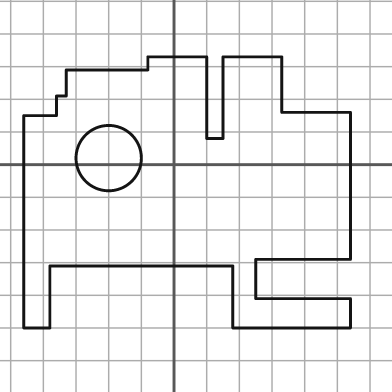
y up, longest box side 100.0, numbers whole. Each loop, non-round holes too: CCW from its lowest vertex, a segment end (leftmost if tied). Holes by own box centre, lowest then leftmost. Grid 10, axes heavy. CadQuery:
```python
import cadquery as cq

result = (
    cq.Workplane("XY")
    .moveTo(-46.0, -50.0)
    .lineTo(-38.0, -50.0)
    .lineTo(-38.0, -31.0)
    .lineTo(18.0, -31.0)
    .lineTo(18.0, -50.0)
    .lineTo(54.0, -50.0)
    .lineTo(54.0, -41.0)
    .lineTo(25.0, -41.0)
    .lineTo(25.0, -29.0)
    .lineTo(54.0, -29.0)
    .lineTo(54.0, 16.0)
    .lineTo(33.0, 16.0)
    .lineTo(33.0, 33.0)
    .lineTo(15.0, 33.0)
    .lineTo(15.0, 8.0)
    .lineTo(10.0, 8.0)
    .lineTo(10.0, 33.0)
    .lineTo(-8.0, 33.0)
    .lineTo(-8.0, 29.0)
    .lineTo(-33.0, 29.0)
    .lineTo(-33.0, 21.0)
    .lineTo(-36.0, 21.0)
    .lineTo(-36.0, 15.0)
    .lineTo(-46.0, 15.0)
    .close()
    .moveTo(-20.0, 2.0)
    .circle(10.0)
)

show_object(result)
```